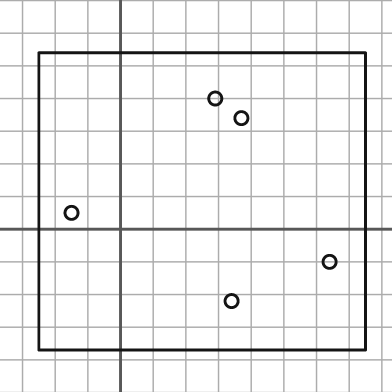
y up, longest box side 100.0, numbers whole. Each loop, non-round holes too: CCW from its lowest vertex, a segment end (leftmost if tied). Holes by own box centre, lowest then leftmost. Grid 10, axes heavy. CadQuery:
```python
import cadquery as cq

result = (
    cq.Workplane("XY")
    .moveTo(-25.0, -37.0)
    .lineTo(75.0, -37.0)
    .lineTo(75.0, 54.0)
    .lineTo(-25.0, 54.0)
    .close()
    .moveTo(34.0, -22.0)
    .circle(2.0)
    .moveTo(64.0, -10.0)
    .circle(2.0)
    .moveTo(-15.0, 5.0)
    .circle(2.0)
    .moveTo(37.0, 34.0)
    .circle(2.0)
    .moveTo(29.0, 40.0)
    .circle(2.0)
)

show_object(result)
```